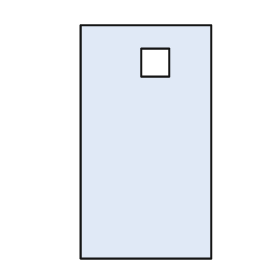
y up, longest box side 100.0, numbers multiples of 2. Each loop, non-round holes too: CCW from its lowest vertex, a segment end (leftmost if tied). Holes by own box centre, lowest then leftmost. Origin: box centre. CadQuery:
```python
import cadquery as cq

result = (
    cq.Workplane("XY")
    .moveTo(-28.0, -50.0)
    .lineTo(28.0, -50.0)
    .lineTo(28.0, 50.0)
    .lineTo(-28.0, 50.0)
    .close()
    .moveTo(-2.0, 28.0)
    .lineTo(10.0, 28.0)
    .lineTo(10.0, 40.0)
    .lineTo(-2.0, 40.0)
    .close()
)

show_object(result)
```